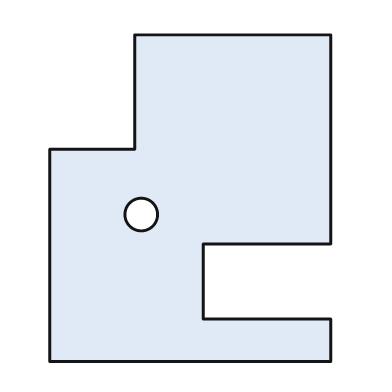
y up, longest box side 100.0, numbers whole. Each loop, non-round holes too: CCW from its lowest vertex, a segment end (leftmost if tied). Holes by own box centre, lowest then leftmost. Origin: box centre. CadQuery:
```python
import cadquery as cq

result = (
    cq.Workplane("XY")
    .moveTo(-43.0, -50.0)
    .lineTo(43.0, -50.0)
    .lineTo(43.0, -37.0)
    .lineTo(4.0, -37.0)
    .lineTo(4.0, -14.0)
    .lineTo(43.0, -14.0)
    .lineTo(43.0, 50.0)
    .lineTo(-17.0, 50.0)
    .lineTo(-17.0, 15.0)
    .lineTo(-43.0, 15.0)
    .close()
    .moveTo(-15.0, -5.0)
    .circle(5.0)
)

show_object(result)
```